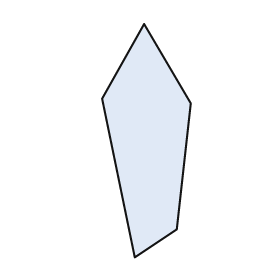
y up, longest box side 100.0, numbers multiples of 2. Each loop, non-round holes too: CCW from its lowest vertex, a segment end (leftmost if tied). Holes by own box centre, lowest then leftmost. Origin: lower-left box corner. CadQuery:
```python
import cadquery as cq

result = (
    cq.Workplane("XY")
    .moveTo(14.0, 0.0)
    .lineTo(32.0, 12.0)
    .lineTo(38.0, 66.0)
    .lineTo(18.0, 100.0)
    .lineTo(0.0, 68.0)
    .close()
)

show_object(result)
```